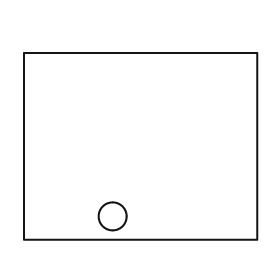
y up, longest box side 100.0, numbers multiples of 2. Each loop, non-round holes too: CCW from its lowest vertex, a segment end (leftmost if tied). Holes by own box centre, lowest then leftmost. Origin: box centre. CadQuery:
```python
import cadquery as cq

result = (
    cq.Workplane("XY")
    .moveTo(-50.0, -40.0)
    .lineTo(50.0, -40.0)
    .lineTo(50.0, 40.0)
    .lineTo(-50.0, 40.0)
    .close()
    .moveTo(-12.0, -30.0)
    .circle(6.0)
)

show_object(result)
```